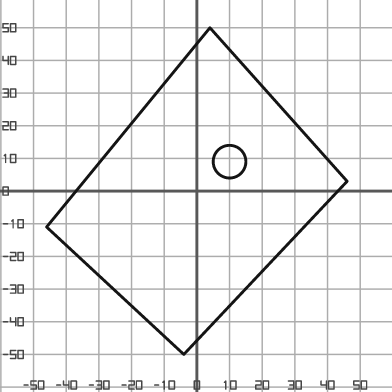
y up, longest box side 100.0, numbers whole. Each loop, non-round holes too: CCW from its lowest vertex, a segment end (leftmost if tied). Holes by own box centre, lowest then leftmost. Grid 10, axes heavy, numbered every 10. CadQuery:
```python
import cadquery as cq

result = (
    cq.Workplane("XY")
    .moveTo(-4.0, -50.0)
    .lineTo(46.0, 3.0)
    .lineTo(4.0, 50.0)
    .lineTo(-46.0, -11.0)
    .close()
    .moveTo(10.0, 9.0)
    .circle(5.0)
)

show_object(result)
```